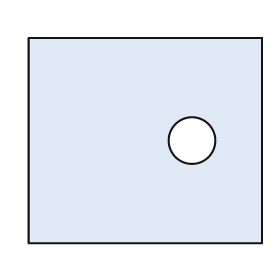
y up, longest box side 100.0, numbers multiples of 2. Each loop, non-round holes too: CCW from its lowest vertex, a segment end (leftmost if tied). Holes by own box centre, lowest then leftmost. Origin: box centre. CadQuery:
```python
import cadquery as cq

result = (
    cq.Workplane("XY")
    .moveTo(-50.0, -44.0)
    .lineTo(50.0, -44.0)
    .lineTo(50.0, 44.0)
    .lineTo(-50.0, 44.0)
    .close()
    .moveTo(20.0, 0.0)
    .circle(10.0)
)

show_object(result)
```